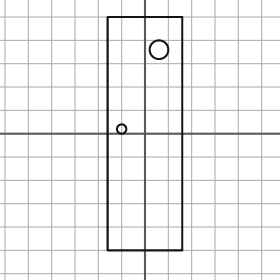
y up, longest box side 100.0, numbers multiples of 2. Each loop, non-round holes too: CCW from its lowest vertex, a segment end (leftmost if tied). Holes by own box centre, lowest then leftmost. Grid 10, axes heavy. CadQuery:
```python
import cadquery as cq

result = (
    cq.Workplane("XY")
    .moveTo(-16.0, -50.0)
    .lineTo(16.0, -50.0)
    .lineTo(16.0, 50.0)
    .lineTo(-16.0, 50.0)
    .close()
    .moveTo(-10.0, 2.0)
    .circle(2.0)
    .moveTo(6.0, 36.0)
    .circle(4.0)
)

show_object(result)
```